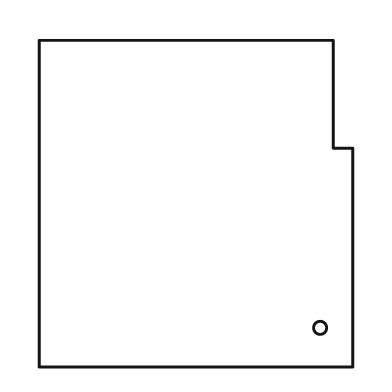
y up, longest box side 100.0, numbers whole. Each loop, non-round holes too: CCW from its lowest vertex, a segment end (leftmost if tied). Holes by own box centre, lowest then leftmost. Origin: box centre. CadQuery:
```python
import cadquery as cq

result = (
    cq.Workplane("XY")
    .moveTo(-48.0, -50.0)
    .lineTo(48.0, -50.0)
    .lineTo(48.0, 17.0)
    .lineTo(42.0, 17.0)
    .lineTo(42.0, 50.0)
    .lineTo(-48.0, 50.0)
    .close()
    .moveTo(38.0, -38.0)
    .circle(2.0)
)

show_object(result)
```